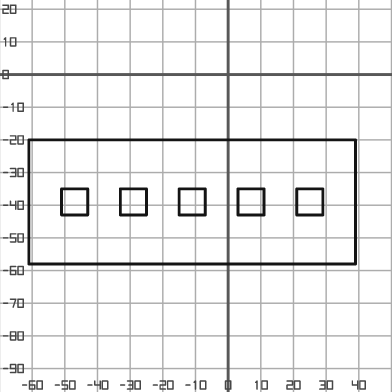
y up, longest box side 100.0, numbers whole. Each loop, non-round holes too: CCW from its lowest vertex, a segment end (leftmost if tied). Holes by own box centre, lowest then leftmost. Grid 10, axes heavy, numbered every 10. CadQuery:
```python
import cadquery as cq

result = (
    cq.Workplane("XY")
    .moveTo(-61.0, -58.0)
    .lineTo(39.0, -58.0)
    .lineTo(39.0, -20.0)
    .lineTo(-61.0, -20.0)
    .close()
    .moveTo(-51.0, -43.0)
    .lineTo(-43.0, -43.0)
    .lineTo(-43.0, -35.0)
    .lineTo(-51.0, -35.0)
    .close()
    .moveTo(-33.0, -43.0)
    .lineTo(-25.0, -43.0)
    .lineTo(-25.0, -35.0)
    .lineTo(-33.0, -35.0)
    .close()
    .moveTo(-15.0, -43.0)
    .lineTo(-7.0, -43.0)
    .lineTo(-7.0, -35.0)
    .lineTo(-15.0, -35.0)
    .close()
    .moveTo(3.0, -43.0)
    .lineTo(11.0, -43.0)
    .lineTo(11.0, -35.0)
    .lineTo(3.0, -35.0)
    .close()
    .moveTo(21.0, -43.0)
    .lineTo(29.0, -43.0)
    .lineTo(29.0, -35.0)
    .lineTo(21.0, -35.0)
    .close()
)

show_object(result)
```